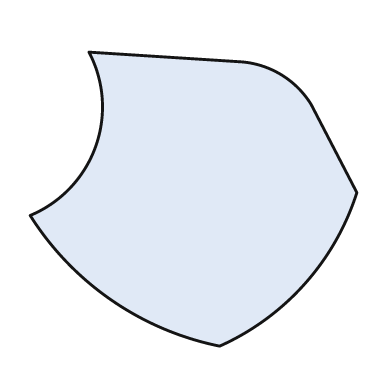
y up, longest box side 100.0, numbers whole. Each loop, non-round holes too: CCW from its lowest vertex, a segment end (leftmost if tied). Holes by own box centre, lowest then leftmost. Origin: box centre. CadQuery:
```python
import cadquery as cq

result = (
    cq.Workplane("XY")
    .moveTo(8.0, -45.0)
    .threePointArc((34.0, -26.0), (50.0, 2.0))
    .lineTo(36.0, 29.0)
    .threePointArc((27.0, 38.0), (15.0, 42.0))
    .lineTo(-32.0, 45.0)
    .threePointArc((-30.0, 16.0), (-50.0, -5.0))
    .threePointArc((-25.0, -31.0), (8.0, -45.0))
    .close()
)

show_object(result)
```